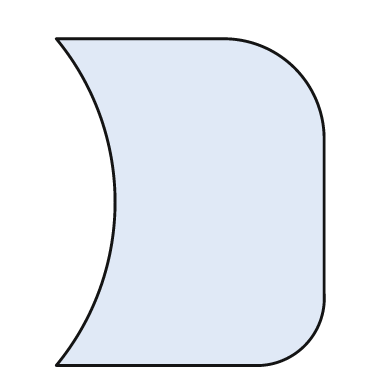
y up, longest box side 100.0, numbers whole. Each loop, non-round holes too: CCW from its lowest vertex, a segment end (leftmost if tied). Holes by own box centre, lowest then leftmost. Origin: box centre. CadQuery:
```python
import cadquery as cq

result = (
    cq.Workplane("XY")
    .moveTo(-41.0, -50.0)
    .lineTo(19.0, -50.0)
    .threePointArc((35.0, -44.0), (41.0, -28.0))
    .lineTo(41.0, 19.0)
    .threePointArc((32.0, 41.0), (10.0, 50.0))
    .lineTo(-41.0, 50.0)
    .threePointArc((-23.0, 0.0), (-41.0, -50.0))
    .close()
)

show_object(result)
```